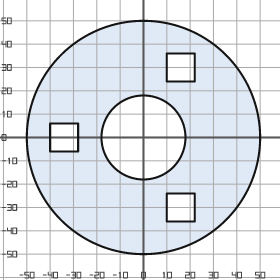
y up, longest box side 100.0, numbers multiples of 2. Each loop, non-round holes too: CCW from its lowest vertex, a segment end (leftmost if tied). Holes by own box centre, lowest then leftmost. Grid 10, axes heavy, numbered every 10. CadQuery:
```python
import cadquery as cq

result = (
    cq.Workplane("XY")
    .moveTo(0.0, 0.0)
    .circle(50.0)
    .moveTo(10.0, -36.0)
    .lineTo(22.0, -36.0)
    .lineTo(22.0, -24.0)
    .lineTo(10.0, -24.0)
    .close()
    .moveTo(-40.0, -6.0)
    .lineTo(-28.0, -6.0)
    .lineTo(-28.0, 6.0)
    .lineTo(-40.0, 6.0)
    .close()
    .moveTo(0.0, 0.0)
    .circle(18.0)
    .moveTo(10.0, 24.0)
    .lineTo(22.0, 24.0)
    .lineTo(22.0, 36.0)
    .lineTo(10.0, 36.0)
    .close()
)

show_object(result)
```